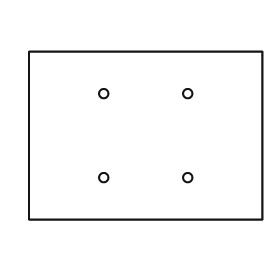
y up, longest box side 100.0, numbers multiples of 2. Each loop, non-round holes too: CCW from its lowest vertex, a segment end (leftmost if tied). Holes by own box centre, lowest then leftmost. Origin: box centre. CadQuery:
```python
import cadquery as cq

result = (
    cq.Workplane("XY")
    .moveTo(-50.0, -36.0)
    .lineTo(50.0, -36.0)
    .lineTo(50.0, 36.0)
    .lineTo(-50.0, 36.0)
    .close()
    .moveTo(-18.0, -18.0)
    .circle(2.0)
    .moveTo(18.0, -18.0)
    .circle(2.0)
    .moveTo(-18.0, 18.0)
    .circle(2.0)
    .moveTo(18.0, 18.0)
    .circle(2.0)
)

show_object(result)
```